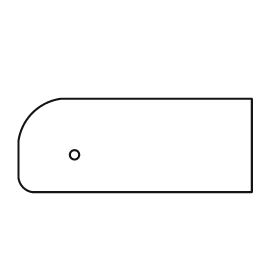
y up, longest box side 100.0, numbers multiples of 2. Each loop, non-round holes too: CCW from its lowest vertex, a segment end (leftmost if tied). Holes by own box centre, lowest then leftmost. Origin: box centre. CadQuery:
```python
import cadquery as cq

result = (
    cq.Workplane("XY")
    .moveTo(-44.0, -20.0)
    .lineTo(50.0, -20.0)
    .lineTo(50.0, 20.0)
    .lineTo(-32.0, 20.0)
    .threePointArc((-44.0, 14.0), (-50.0, 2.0))
    .lineTo(-50.0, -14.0)
    .threePointArc((-48.0, -18.0), (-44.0, -20.0))
    .close()
    .moveTo(-26.0, -4.0)
    .circle(2.0)
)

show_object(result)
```